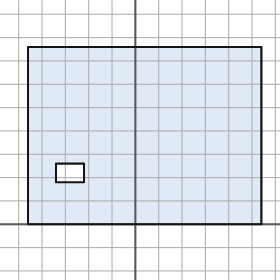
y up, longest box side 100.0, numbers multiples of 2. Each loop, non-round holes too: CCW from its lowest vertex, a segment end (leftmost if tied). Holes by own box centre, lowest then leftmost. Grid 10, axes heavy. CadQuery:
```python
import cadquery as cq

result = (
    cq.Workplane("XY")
    .moveTo(-46.0, 0.0)
    .lineTo(54.0, 0.0)
    .lineTo(54.0, 76.0)
    .lineTo(-46.0, 76.0)
    .close()
    .moveTo(-34.0, 18.0)
    .lineTo(-22.0, 18.0)
    .lineTo(-22.0, 26.0)
    .lineTo(-34.0, 26.0)
    .close()
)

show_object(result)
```